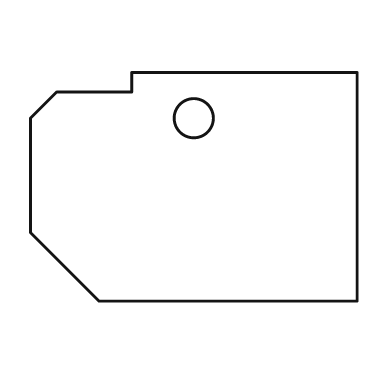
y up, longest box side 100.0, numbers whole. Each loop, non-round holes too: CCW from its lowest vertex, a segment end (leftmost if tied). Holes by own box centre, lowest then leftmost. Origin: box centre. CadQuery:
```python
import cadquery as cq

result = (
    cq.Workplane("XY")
    .moveTo(-29.0, -35.0)
    .lineTo(50.0, -35.0)
    .lineTo(50.0, 35.0)
    .lineTo(-19.0, 35.0)
    .lineTo(-19.0, 29.0)
    .lineTo(-42.0, 29.0)
    .lineTo(-50.0, 21.0)
    .lineTo(-50.0, -14.0)
    .close()
    .moveTo(0.0, 21.0)
    .circle(6.0)
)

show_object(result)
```